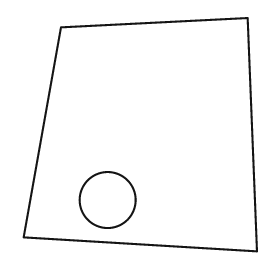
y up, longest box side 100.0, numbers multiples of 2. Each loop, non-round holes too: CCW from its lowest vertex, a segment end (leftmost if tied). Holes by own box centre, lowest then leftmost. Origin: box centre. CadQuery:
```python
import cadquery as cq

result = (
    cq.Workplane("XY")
    .moveTo(50.0, -50.0)
    .lineTo(46.0, 50.0)
    .lineTo(-34.0, 46.0)
    .lineTo(-50.0, -44.0)
    .close()
    .moveTo(-14.0, -28.0)
    .circle(12.0)
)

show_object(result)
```